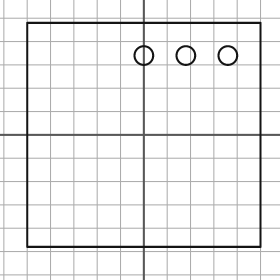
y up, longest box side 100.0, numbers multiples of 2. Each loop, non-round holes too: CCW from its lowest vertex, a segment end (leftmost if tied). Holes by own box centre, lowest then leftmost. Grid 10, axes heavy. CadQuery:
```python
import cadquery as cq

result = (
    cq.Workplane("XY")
    .moveTo(-50.0, -48.0)
    .lineTo(50.0, -48.0)
    .lineTo(50.0, 48.0)
    .lineTo(-50.0, 48.0)
    .close()
    .moveTo(0.0, 34.0)
    .circle(4.0)
    .moveTo(18.0, 34.0)
    .circle(4.0)
    .moveTo(36.0, 34.0)
    .circle(4.0)
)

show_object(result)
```